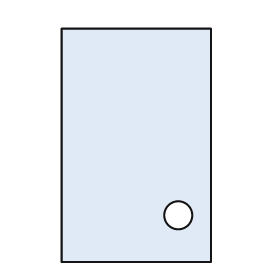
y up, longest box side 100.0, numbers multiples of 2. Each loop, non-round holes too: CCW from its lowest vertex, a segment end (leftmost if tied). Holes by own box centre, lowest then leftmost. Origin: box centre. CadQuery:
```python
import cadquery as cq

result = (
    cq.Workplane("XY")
    .moveTo(-32.0, -50.0)
    .lineTo(32.0, -50.0)
    .lineTo(32.0, 50.0)
    .lineTo(-32.0, 50.0)
    .close()
    .moveTo(18.0, -30.0)
    .circle(6.0)
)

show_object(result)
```